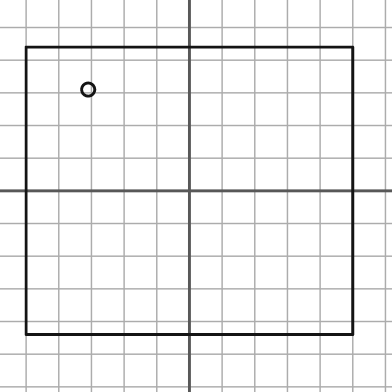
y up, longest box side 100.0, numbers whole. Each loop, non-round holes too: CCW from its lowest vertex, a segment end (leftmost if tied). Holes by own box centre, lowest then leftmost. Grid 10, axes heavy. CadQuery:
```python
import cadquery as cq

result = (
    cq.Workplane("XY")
    .moveTo(-50.0, -44.0)
    .lineTo(50.0, -44.0)
    .lineTo(50.0, 44.0)
    .lineTo(-50.0, 44.0)
    .close()
    .moveTo(-31.0, 31.0)
    .circle(2.0)
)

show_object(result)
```